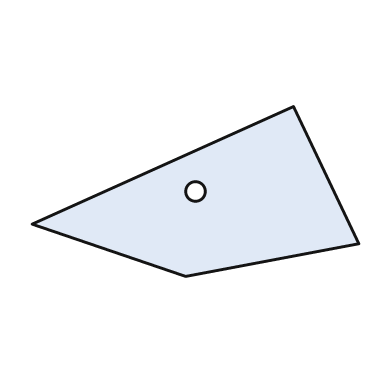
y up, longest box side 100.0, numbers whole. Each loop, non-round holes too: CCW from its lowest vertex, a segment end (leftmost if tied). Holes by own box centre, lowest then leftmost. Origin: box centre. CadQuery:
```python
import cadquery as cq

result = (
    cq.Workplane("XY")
    .moveTo(-3.0, -26.0)
    .lineTo(50.0, -16.0)
    .lineTo(30.0, 26.0)
    .lineTo(-50.0, -10.0)
    .close()
    .moveTo(0.0, 0.0)
    .circle(3.0)
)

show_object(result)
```